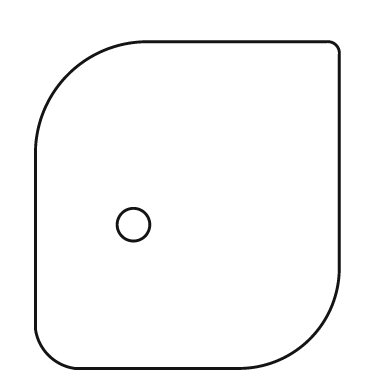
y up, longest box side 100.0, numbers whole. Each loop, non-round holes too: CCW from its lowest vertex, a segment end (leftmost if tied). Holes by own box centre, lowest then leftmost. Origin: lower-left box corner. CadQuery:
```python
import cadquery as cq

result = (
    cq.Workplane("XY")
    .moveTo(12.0, 0.0)
    .lineTo(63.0, 0.0)
    .threePointArc((84.0, 9.0), (93.0, 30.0))
    .lineTo(93.0, 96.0)
    .threePointArc((92.0, 99.0), (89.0, 100.0))
    .lineTo(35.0, 100.0)
    .threePointArc((10.0, 90.0), (0.0, 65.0))
    .lineTo(0.0, 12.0)
    .threePointArc((4.0, 4.0), (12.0, 0.0))
    .close()
    .moveTo(30.0, 44.0)
    .circle(5.0)
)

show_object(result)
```